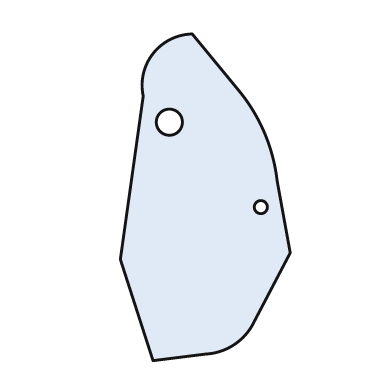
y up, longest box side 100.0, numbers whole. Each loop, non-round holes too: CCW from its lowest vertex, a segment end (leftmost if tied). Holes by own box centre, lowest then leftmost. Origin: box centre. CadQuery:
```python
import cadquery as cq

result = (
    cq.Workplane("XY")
    .moveTo(-16.0, -50.0)
    .lineTo(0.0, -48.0)
    .threePointArc((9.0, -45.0), (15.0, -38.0))
    .lineTo(26.0, -17.0)
    .lineTo(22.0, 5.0)
    .threePointArc((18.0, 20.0), (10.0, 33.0))
    .lineTo(-4.0, 50.0)
    .threePointArc((-16.0, 44.0), (-19.0, 31.0))
    .lineTo(-26.0, -19.0)
    .close()
    .moveTo(17.0, -3.0)
    .circle(2.0)
    .moveTo(-11.0, 23.0)
    .circle(4.0)
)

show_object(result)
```